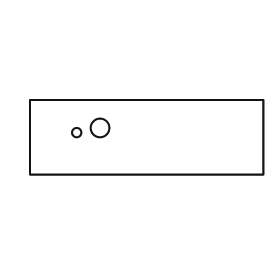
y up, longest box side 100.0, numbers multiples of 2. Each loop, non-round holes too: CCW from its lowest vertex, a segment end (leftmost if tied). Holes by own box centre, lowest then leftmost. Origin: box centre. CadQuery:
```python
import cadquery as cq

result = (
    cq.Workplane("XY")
    .moveTo(-50.0, -16.0)
    .lineTo(50.0, -16.0)
    .lineTo(50.0, 16.0)
    .lineTo(-50.0, 16.0)
    .close()
    .moveTo(-30.0, 2.0)
    .circle(2.0)
    .moveTo(-20.0, 4.0)
    .circle(4.0)
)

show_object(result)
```